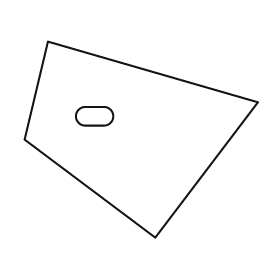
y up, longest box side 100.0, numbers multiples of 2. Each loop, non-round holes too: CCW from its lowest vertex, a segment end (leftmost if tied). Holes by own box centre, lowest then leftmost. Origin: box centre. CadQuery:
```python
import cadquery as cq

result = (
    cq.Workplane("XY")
    .moveTo(6.0, -42.0)
    .lineTo(50.0, 16.0)
    .lineTo(-40.0, 42.0)
    .lineTo(-50.0, 0.0)
    .close()
    .moveTo(-24.0, 6.0)
    .lineTo(-16.0, 6.0)
    .threePointArc((-12.0, 10.0), (-16.0, 14.0))
    .lineTo(-24.0, 14.0)
    .threePointArc((-28.0, 10.0), (-24.0, 6.0))
    .close()
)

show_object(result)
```